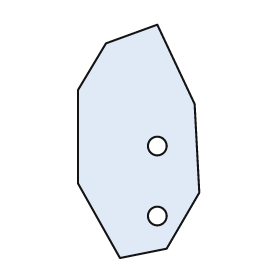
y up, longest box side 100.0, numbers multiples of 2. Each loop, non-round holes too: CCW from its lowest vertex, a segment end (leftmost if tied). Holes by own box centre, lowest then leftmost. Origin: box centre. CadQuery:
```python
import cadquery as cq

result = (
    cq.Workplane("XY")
    .moveTo(-8.0, -50.0)
    .lineTo(12.0, -46.0)
    .lineTo(26.0, -22.0)
    .lineTo(24.0, 16.0)
    .lineTo(8.0, 50.0)
    .lineTo(-14.0, 42.0)
    .lineTo(-26.0, 22.0)
    .lineTo(-26.0, -18.0)
    .close()
    .moveTo(8.0, -32.0)
    .circle(4.0)
    .moveTo(8.0, -2.0)
    .circle(4.0)
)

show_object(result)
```